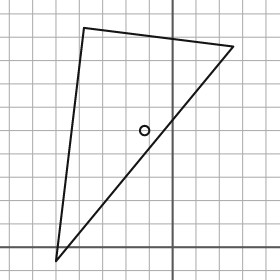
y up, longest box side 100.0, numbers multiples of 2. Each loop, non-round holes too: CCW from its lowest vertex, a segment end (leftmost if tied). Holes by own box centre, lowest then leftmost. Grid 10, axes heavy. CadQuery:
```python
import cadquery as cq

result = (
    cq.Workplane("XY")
    .moveTo(-50.0, -6.0)
    .lineTo(26.0, 86.0)
    .lineTo(-38.0, 94.0)
    .close()
    .moveTo(-12.0, 50.0)
    .circle(2.0)
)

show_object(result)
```